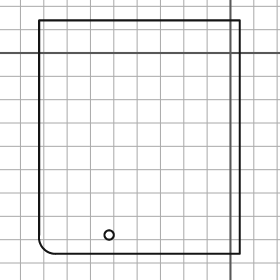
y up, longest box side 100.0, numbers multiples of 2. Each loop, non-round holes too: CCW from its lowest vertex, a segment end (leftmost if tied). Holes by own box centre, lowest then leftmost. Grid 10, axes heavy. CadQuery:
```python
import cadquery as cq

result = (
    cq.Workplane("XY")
    .moveTo(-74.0, -86.0)
    .lineTo(4.0, -86.0)
    .lineTo(4.0, 14.0)
    .lineTo(-82.0, 14.0)
    .lineTo(-82.0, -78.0)
    .threePointArc((-80.0, -84.0), (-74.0, -86.0))
    .close()
    .moveTo(-52.0, -78.0)
    .circle(2.0)
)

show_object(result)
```